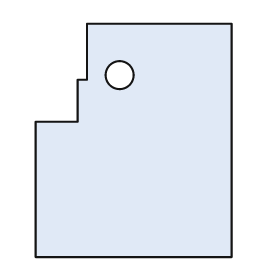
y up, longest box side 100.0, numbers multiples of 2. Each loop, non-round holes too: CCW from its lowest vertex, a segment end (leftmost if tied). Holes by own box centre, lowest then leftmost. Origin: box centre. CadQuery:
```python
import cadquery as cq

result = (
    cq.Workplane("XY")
    .moveTo(-42.0, -50.0)
    .lineTo(42.0, -50.0)
    .lineTo(42.0, 50.0)
    .lineTo(-20.0, 50.0)
    .lineTo(-20.0, 26.0)
    .lineTo(-24.0, 26.0)
    .lineTo(-24.0, 8.0)
    .lineTo(-42.0, 8.0)
    .close()
    .moveTo(-6.0, 28.0)
    .circle(6.0)
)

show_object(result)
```